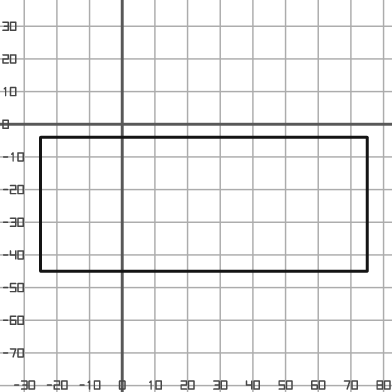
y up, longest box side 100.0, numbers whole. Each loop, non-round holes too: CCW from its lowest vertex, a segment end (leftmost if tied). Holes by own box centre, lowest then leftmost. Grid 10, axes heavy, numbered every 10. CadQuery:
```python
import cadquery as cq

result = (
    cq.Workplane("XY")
    .moveTo(-25.0, -45.0)
    .lineTo(75.0, -45.0)
    .lineTo(75.0, -4.0)
    .lineTo(-25.0, -4.0)
    .close()
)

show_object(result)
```